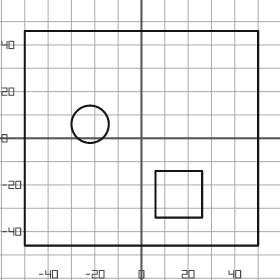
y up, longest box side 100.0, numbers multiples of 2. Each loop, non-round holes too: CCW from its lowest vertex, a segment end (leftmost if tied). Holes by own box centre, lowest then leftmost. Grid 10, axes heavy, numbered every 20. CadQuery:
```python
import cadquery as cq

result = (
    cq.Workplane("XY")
    .moveTo(-50.0, -46.0)
    .lineTo(50.0, -46.0)
    .lineTo(50.0, 46.0)
    .lineTo(-50.0, 46.0)
    .close()
    .moveTo(6.0, -34.0)
    .lineTo(26.0, -34.0)
    .lineTo(26.0, -14.0)
    .lineTo(6.0, -14.0)
    .close()
    .moveTo(-22.0, 6.0)
    .circle(8.0)
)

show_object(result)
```